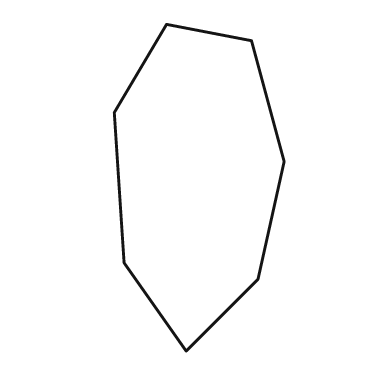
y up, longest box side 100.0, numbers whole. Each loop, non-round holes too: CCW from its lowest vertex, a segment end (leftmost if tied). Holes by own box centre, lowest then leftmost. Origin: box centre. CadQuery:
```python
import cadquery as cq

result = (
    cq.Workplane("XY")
    .moveTo(-4.0, -50.0)
    .lineTo(18.0, -28.0)
    .lineTo(26.0, 8.0)
    .lineTo(16.0, 45.0)
    .lineTo(-10.0, 50.0)
    .lineTo(-26.0, 23.0)
    .lineTo(-23.0, -23.0)
    .close()
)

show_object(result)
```